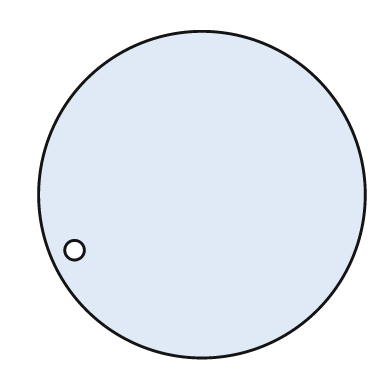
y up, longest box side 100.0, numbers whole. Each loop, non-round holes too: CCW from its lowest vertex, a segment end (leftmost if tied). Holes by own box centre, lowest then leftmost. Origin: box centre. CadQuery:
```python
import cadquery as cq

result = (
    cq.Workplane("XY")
    .moveTo(0.0, 0.0)
    .circle(50.0)
    .moveTo(-39.0, -17.0)
    .circle(3.0)
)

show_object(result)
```